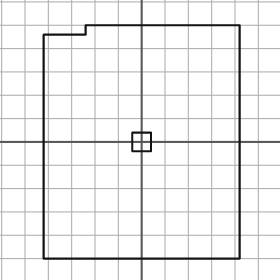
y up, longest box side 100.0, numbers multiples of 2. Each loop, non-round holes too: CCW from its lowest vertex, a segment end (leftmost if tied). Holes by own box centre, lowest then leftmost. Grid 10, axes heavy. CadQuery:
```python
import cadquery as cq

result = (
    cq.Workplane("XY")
    .moveTo(-42.0, -50.0)
    .lineTo(42.0, -50.0)
    .lineTo(42.0, 50.0)
    .lineTo(-24.0, 50.0)
    .lineTo(-24.0, 46.0)
    .lineTo(-42.0, 46.0)
    .close()
    .moveTo(-4.0, -4.0)
    .lineTo(4.0, -4.0)
    .lineTo(4.0, 4.0)
    .lineTo(-4.0, 4.0)
    .close()
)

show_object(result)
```